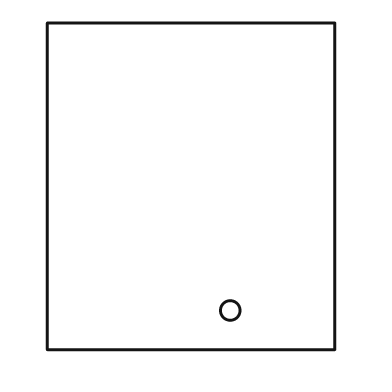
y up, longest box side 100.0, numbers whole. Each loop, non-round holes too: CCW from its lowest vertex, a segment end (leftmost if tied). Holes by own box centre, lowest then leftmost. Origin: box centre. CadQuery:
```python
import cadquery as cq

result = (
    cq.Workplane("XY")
    .moveTo(-44.0, -50.0)
    .lineTo(44.0, -50.0)
    .lineTo(44.0, 50.0)
    .lineTo(-44.0, 50.0)
    .close()
    .moveTo(12.0, -38.0)
    .circle(3.0)
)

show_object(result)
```